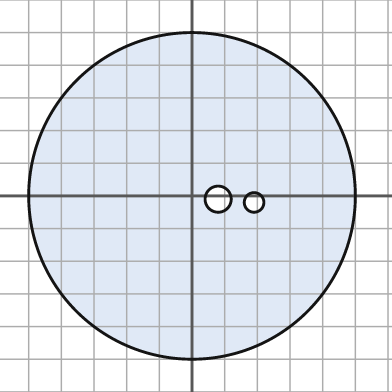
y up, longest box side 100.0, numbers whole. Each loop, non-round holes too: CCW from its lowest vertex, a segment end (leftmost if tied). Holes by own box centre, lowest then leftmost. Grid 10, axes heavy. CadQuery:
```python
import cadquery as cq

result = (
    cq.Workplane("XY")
    .moveTo(0.0, 0.0)
    .circle(50.0)
    .moveTo(19.0, -2.0)
    .circle(3.0)
    .moveTo(8.0, -1.0)
    .circle(4.0)
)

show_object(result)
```